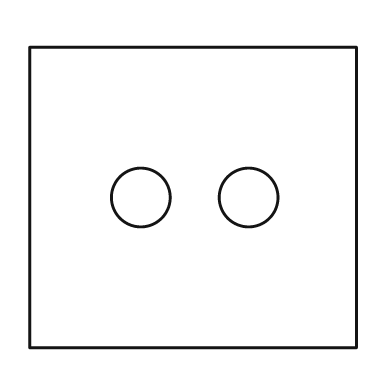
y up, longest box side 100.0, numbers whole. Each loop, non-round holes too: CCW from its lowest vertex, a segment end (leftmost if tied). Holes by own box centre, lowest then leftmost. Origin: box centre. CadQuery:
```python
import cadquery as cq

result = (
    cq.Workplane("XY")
    .moveTo(-50.0, -46.0)
    .lineTo(50.0, -46.0)
    .lineTo(50.0, 46.0)
    .lineTo(-50.0, 46.0)
    .close()
    .moveTo(-16.0, 0.0)
    .circle(9.0)
    .moveTo(17.0, 0.0)
    .circle(9.0)
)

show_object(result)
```